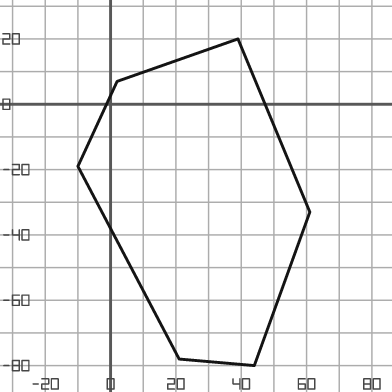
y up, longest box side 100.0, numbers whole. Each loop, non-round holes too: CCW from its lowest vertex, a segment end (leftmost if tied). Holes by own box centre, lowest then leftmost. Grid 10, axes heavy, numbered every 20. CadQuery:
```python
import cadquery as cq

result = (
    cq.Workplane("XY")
    .moveTo(44.0, -80.0)
    .lineTo(61.0, -33.0)
    .lineTo(39.0, 20.0)
    .lineTo(2.0, 7.0)
    .lineTo(-10.0, -19.0)
    .lineTo(21.0, -78.0)
    .close()
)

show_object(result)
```